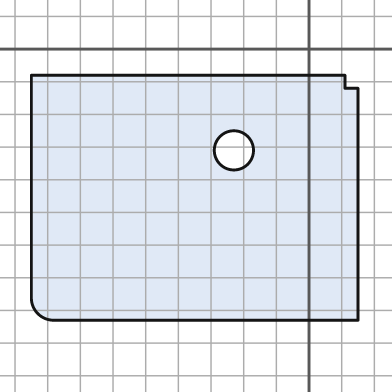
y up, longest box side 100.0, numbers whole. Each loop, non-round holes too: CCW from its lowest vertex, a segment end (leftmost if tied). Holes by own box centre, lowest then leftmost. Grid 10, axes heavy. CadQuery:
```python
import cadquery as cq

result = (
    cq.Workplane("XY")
    .moveTo(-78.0, -83.0)
    .lineTo(15.0, -83.0)
    .lineTo(15.0, -12.0)
    .lineTo(11.0, -12.0)
    .lineTo(11.0, -8.0)
    .lineTo(-85.0, -8.0)
    .lineTo(-85.0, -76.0)
    .threePointArc((-83.0, -81.0), (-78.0, -83.0))
    .close()
    .moveTo(-23.0, -31.0)
    .circle(6.0)
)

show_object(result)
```